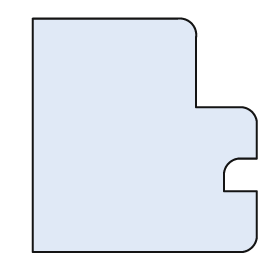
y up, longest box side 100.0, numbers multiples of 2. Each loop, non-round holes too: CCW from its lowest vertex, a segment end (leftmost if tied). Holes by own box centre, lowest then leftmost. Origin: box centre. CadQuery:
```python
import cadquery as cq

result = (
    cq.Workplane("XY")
    .moveTo(-48.0, -50.0)
    .lineTo(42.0, -50.0)
    .threePointArc((46.0, -48.0), (48.0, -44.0))
    .lineTo(48.0, -24.0)
    .lineTo(34.0, -24.0)
    .lineTo(34.0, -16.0)
    .threePointArc((36.0, -12.0), (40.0, -10.0))
    .lineTo(48.0, -10.0)
    .lineTo(48.0, 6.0)
    .threePointArc((46.0, 10.0), (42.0, 12.0))
    .lineTo(22.0, 12.0)
    .lineTo(22.0, 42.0)
    .threePointArc((20.0, 48.0), (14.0, 50.0))
    .lineTo(-48.0, 50.0)
    .close()
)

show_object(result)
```